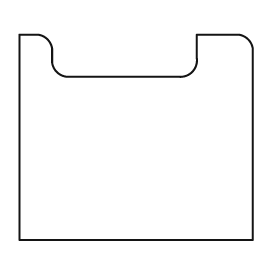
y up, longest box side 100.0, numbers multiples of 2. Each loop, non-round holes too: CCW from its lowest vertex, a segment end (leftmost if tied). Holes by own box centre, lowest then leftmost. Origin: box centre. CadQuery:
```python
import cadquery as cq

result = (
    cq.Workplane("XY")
    .moveTo(-50.0, -44.0)
    .lineTo(50.0, -44.0)
    .lineTo(50.0, 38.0)
    .threePointArc((48.0, 42.0), (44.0, 44.0))
    .lineTo(26.0, 44.0)
    .lineTo(26.0, 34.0)
    .threePointArc((24.0, 28.0), (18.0, 26.0))
    .lineTo(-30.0, 26.0)
    .threePointArc((-34.0, 28.0), (-36.0, 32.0))
    .lineTo(-36.0, 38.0)
    .threePointArc((-38.0, 42.0), (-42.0, 44.0))
    .lineTo(-50.0, 44.0)
    .close()
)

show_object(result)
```